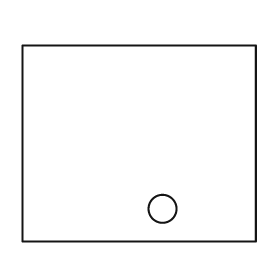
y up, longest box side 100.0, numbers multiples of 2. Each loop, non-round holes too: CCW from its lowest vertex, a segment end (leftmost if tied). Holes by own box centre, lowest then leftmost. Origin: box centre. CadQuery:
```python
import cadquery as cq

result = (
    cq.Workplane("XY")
    .moveTo(-50.0, -42.0)
    .lineTo(50.0, -42.0)
    .lineTo(50.0, 42.0)
    .lineTo(-50.0, 42.0)
    .close()
    .moveTo(10.0, -28.0)
    .circle(6.0)
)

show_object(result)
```